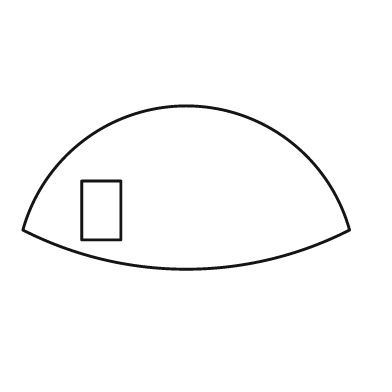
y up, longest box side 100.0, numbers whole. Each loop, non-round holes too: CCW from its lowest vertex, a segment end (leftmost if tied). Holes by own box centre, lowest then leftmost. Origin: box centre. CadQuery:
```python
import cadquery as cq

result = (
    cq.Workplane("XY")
    .moveTo(-50.0, -13.0)
    .threePointArc((0.0, -25.0), (50.0, -13.0))
    .threePointArc((0.0, 25.0), (-50.0, -13.0))
    .close()
    .moveTo(-32.0, -16.0)
    .lineTo(-20.0, -16.0)
    .lineTo(-20.0, 2.0)
    .lineTo(-32.0, 2.0)
    .close()
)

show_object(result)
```